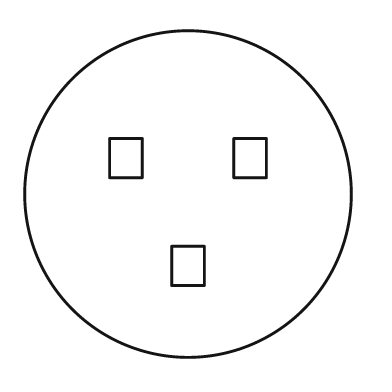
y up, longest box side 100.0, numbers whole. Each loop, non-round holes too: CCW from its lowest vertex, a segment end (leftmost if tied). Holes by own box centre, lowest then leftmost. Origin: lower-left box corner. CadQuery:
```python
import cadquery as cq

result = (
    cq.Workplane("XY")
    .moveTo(50.0, 50.0)
    .circle(50.0)
    .moveTo(45.0, 22.0)
    .lineTo(55.0, 22.0)
    .lineTo(55.0, 34.0)
    .lineTo(45.0, 34.0)
    .close()
    .moveTo(26.0, 55.0)
    .lineTo(36.0, 55.0)
    .lineTo(36.0, 67.0)
    .lineTo(26.0, 67.0)
    .close()
    .moveTo(64.0, 55.0)
    .lineTo(74.0, 55.0)
    .lineTo(74.0, 67.0)
    .lineTo(64.0, 67.0)
    .close()
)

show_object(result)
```